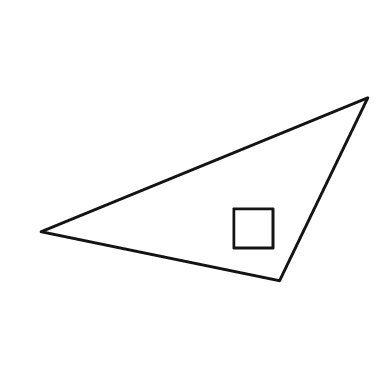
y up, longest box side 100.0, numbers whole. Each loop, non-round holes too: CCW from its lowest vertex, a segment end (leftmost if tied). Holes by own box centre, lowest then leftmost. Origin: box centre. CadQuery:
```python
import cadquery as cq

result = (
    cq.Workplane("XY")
    .moveTo(23.0, -28.0)
    .lineTo(50.0, 28.0)
    .lineTo(-50.0, -13.0)
    .close()
    .moveTo(9.0, -18.0)
    .lineTo(21.0, -18.0)
    .lineTo(21.0, -6.0)
    .lineTo(9.0, -6.0)
    .close()
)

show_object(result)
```